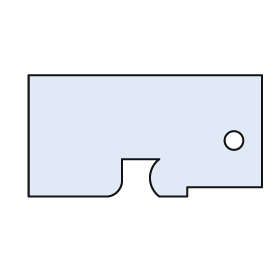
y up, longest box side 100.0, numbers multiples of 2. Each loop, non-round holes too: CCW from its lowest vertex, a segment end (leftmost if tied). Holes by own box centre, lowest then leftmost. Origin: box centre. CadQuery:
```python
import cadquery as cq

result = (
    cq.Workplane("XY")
    .moveTo(-50.0, -26.0)
    .lineTo(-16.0, -26.0)
    .threePointArc((-12.0, -24.0), (-10.0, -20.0))
    .lineTo(-10.0, -10.0)
    .lineTo(6.0, -10.0)
    .threePointArc((2.0, -18.0), (6.0, -26.0))
    .lineTo(18.0, -26.0)
    .lineTo(18.0, -22.0)
    .lineTo(50.0, -22.0)
    .lineTo(50.0, 26.0)
    .lineTo(-50.0, 26.0)
    .close()
    .moveTo(38.0, -2.0)
    .circle(4.0)
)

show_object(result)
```